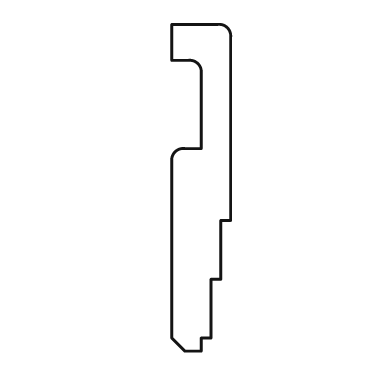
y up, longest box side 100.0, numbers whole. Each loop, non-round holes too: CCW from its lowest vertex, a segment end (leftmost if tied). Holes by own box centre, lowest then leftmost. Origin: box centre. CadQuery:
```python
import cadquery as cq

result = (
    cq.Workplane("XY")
    .moveTo(-5.0, -50.0)
    .lineTo(0.0, -50.0)
    .lineTo(0.0, -46.0)
    .lineTo(3.0, -46.0)
    .lineTo(3.0, -28.0)
    .lineTo(6.0, -28.0)
    .lineTo(6.0, -10.0)
    .lineTo(9.0, -10.0)
    .lineTo(9.0, 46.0)
    .threePointArc((8.0, 49.0), (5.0, 50.0))
    .lineTo(-9.0, 50.0)
    .lineTo(-9.0, 39.0)
    .lineTo(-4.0, 39.0)
    .threePointArc((-1.0, 38.0), (0.0, 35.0))
    .lineTo(0.0, 12.0)
    .lineTo(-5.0, 12.0)
    .threePointArc((-8.0, 11.0), (-9.0, 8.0))
    .lineTo(-9.0, -46.0)
    .close()
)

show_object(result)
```